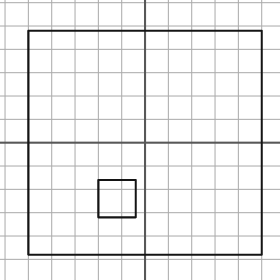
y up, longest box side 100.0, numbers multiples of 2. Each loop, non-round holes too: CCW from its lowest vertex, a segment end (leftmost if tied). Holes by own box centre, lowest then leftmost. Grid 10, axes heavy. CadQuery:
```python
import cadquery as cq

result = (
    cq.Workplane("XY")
    .moveTo(-50.0, -48.0)
    .lineTo(50.0, -48.0)
    .lineTo(50.0, 48.0)
    .lineTo(-50.0, 48.0)
    .close()
    .moveTo(-20.0, -32.0)
    .lineTo(-4.0, -32.0)
    .lineTo(-4.0, -16.0)
    .lineTo(-20.0, -16.0)
    .close()
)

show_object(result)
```